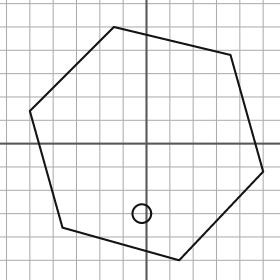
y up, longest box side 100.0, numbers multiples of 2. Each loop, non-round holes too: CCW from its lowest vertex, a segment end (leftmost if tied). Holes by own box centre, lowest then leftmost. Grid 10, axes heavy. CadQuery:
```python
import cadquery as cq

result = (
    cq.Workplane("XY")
    .moveTo(14.0, -50.0)
    .lineTo(50.0, -12.0)
    .lineTo(36.0, 38.0)
    .lineTo(-14.0, 50.0)
    .lineTo(-50.0, 14.0)
    .lineTo(-36.0, -36.0)
    .close()
    .moveTo(-2.0, -30.0)
    .circle(4.0)
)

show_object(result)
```